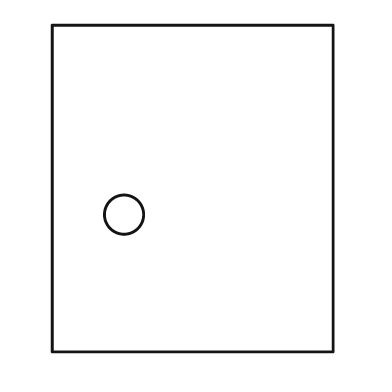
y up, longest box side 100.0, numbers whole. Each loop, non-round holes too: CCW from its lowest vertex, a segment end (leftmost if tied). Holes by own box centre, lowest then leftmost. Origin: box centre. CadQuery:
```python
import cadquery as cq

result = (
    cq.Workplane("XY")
    .moveTo(-43.0, -50.0)
    .lineTo(43.0, -50.0)
    .lineTo(43.0, 50.0)
    .lineTo(-43.0, 50.0)
    .close()
    .moveTo(-21.0, -8.0)
    .circle(6.0)
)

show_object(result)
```